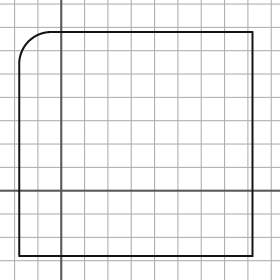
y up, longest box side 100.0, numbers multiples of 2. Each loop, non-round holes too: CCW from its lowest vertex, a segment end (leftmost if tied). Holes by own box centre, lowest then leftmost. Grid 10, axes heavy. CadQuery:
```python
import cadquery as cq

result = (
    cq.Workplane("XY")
    .moveTo(-18.0, -28.0)
    .lineTo(82.0, -28.0)
    .lineTo(82.0, 68.0)
    .lineTo(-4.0, 68.0)
    .threePointArc((-14.0, 64.0), (-18.0, 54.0))
    .close()
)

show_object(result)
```